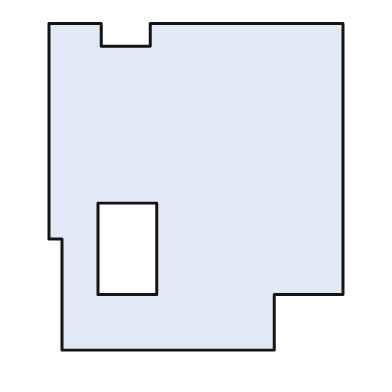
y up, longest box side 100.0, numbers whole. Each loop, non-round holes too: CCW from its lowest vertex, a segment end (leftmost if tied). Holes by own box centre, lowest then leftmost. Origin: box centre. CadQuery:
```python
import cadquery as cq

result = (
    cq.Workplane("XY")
    .moveTo(-41.0, -50.0)
    .lineTo(24.0, -50.0)
    .lineTo(24.0, -33.0)
    .lineTo(45.0, -33.0)
    .lineTo(45.0, 50.0)
    .lineTo(-14.0, 50.0)
    .lineTo(-14.0, 43.0)
    .lineTo(-29.0, 43.0)
    .lineTo(-29.0, 50.0)
    .lineTo(-45.0, 50.0)
    .lineTo(-45.0, -16.0)
    .lineTo(-41.0, -16.0)
    .close()
    .moveTo(-30.0, -33.0)
    .lineTo(-12.0, -33.0)
    .lineTo(-12.0, -5.0)
    .lineTo(-30.0, -5.0)
    .close()
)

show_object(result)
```